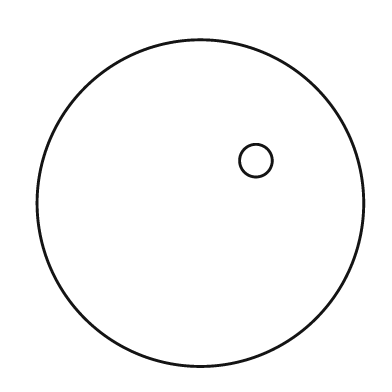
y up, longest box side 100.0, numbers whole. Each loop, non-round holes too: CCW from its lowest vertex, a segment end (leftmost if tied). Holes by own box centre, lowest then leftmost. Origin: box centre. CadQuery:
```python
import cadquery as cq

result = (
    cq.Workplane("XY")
    .moveTo(0.0, 0.0)
    .circle(50.0)
    .moveTo(17.0, 13.0)
    .circle(5.0)
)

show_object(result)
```